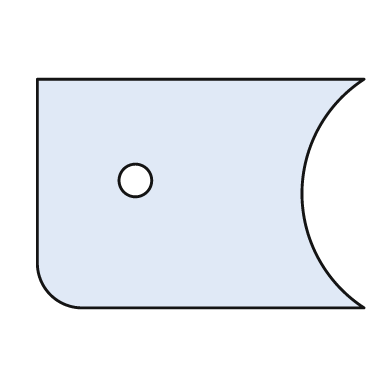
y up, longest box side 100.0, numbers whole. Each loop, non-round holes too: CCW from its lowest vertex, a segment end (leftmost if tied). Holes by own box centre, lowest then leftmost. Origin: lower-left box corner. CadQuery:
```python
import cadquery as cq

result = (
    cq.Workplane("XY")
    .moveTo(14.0, 0.0)
    .lineTo(100.0, 0.0)
    .threePointArc((81.0, 35.0), (100.0, 70.0))
    .lineTo(0.0, 70.0)
    .lineTo(0.0, 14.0)
    .threePointArc((4.0, 4.0), (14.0, 0.0))
    .close()
    .moveTo(30.0, 39.0)
    .circle(5.0)
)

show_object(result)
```